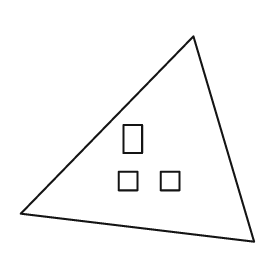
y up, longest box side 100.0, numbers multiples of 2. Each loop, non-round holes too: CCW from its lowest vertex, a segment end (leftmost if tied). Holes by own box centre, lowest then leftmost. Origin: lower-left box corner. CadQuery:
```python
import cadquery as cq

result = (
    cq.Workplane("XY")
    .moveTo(100.0, 0.0)
    .lineTo(74.0, 88.0)
    .lineTo(0.0, 12.0)
    .close()
    .moveTo(42.0, 22.0)
    .lineTo(50.0, 22.0)
    .lineTo(50.0, 30.0)
    .lineTo(42.0, 30.0)
    .close()
    .moveTo(60.0, 22.0)
    .lineTo(68.0, 22.0)
    .lineTo(68.0, 30.0)
    .lineTo(60.0, 30.0)
    .close()
    .moveTo(44.0, 38.0)
    .lineTo(52.0, 38.0)
    .lineTo(52.0, 50.0)
    .lineTo(44.0, 50.0)
    .close()
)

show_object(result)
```